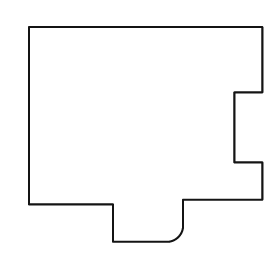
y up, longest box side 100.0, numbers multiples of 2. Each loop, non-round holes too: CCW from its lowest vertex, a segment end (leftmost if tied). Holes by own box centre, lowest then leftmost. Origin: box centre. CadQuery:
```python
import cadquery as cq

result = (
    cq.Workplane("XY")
    .moveTo(-14.0, -46.0)
    .lineTo(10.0, -46.0)
    .threePointArc((14.0, -44.0), (16.0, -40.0))
    .lineTo(16.0, -28.0)
    .lineTo(50.0, -28.0)
    .lineTo(50.0, -12.0)
    .lineTo(38.0, -12.0)
    .lineTo(38.0, 18.0)
    .lineTo(50.0, 18.0)
    .lineTo(50.0, 46.0)
    .lineTo(-50.0, 46.0)
    .lineTo(-50.0, -30.0)
    .lineTo(-14.0, -30.0)
    .close()
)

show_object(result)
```